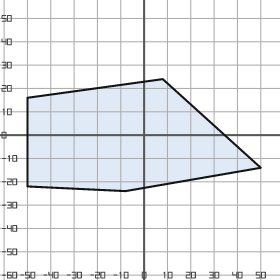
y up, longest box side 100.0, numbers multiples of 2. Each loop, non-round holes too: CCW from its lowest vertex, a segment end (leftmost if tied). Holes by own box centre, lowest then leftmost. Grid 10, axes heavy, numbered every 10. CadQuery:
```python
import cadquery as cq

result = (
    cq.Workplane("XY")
    .moveTo(-8.0, -24.0)
    .lineTo(50.0, -14.0)
    .lineTo(8.0, 24.0)
    .lineTo(-50.0, 16.0)
    .lineTo(-50.0, -22.0)
    .close()
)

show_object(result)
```